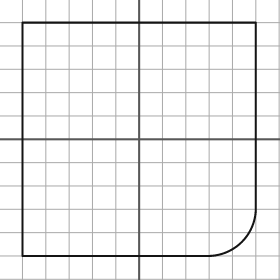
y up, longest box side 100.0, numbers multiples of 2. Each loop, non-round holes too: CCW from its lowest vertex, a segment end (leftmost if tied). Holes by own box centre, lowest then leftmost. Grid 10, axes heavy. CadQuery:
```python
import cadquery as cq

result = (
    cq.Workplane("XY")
    .moveTo(-50.0, -50.0)
    .lineTo(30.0, -50.0)
    .threePointArc((44.0, -44.0), (50.0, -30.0))
    .lineTo(50.0, 50.0)
    .lineTo(-50.0, 50.0)
    .close()
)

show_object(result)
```